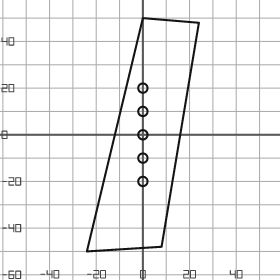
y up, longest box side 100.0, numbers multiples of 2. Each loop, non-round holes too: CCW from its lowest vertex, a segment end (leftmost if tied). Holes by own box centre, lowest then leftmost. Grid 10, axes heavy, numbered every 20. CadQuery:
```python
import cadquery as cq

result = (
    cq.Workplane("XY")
    .moveTo(-24.0, -50.0)
    .lineTo(8.0, -48.0)
    .lineTo(24.0, 48.0)
    .lineTo(0.0, 50.0)
    .close()
    .moveTo(0.0, -20.0)
    .circle(2.0)
    .moveTo(0.0, -10.0)
    .circle(2.0)
    .moveTo(0.0, 0.0)
    .circle(2.0)
    .moveTo(0.0, 10.0)
    .circle(2.0)
    .moveTo(0.0, 20.0)
    .circle(2.0)
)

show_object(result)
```